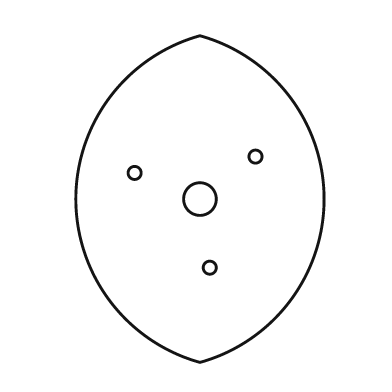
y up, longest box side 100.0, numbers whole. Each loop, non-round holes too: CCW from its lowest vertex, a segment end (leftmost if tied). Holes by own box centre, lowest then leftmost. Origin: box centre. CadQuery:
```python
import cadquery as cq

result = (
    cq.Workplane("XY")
    .moveTo(0.0, -50.0)
    .threePointArc((38.0, 0.0), (0.0, 50.0))
    .threePointArc((-38.0, 0.0), (0.0, -50.0))
    .close()
    .moveTo(3.0, -21.0)
    .circle(2.0)
    .moveTo(0.0, 0.0)
    .circle(5.0)
    .moveTo(-20.0, 8.0)
    .circle(2.0)
    .moveTo(17.0, 13.0)
    .circle(2.0)
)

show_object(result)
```